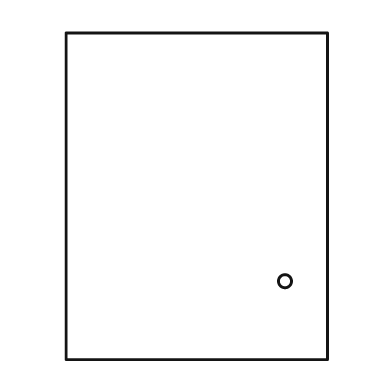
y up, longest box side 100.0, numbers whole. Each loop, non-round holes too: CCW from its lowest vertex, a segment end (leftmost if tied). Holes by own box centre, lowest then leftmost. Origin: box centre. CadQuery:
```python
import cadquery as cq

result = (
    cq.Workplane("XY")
    .moveTo(-40.0, -50.0)
    .lineTo(40.0, -50.0)
    .lineTo(40.0, 50.0)
    .lineTo(-40.0, 50.0)
    .close()
    .moveTo(27.0, -26.0)
    .circle(2.0)
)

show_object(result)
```